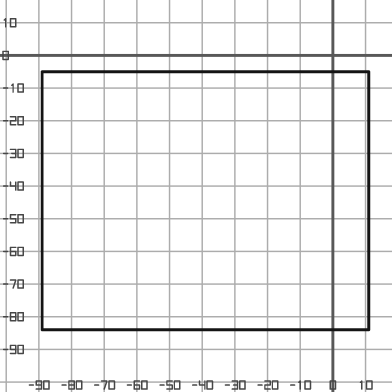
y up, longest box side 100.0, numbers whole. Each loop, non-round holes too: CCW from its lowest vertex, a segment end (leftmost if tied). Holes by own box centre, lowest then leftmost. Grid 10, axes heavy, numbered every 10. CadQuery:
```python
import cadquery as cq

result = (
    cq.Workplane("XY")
    .moveTo(-89.0, -84.0)
    .lineTo(11.0, -84.0)
    .lineTo(11.0, -5.0)
    .lineTo(-89.0, -5.0)
    .close()
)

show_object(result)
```